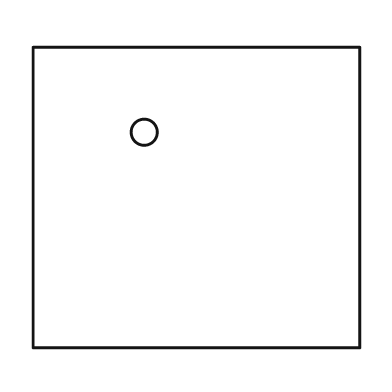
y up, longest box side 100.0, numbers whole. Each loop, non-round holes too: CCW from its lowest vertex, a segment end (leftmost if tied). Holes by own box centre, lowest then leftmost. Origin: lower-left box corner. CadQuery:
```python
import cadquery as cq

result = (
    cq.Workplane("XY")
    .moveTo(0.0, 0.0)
    .lineTo(100.0, 0.0)
    .lineTo(100.0, 92.0)
    .lineTo(0.0, 92.0)
    .close()
    .moveTo(34.0, 66.0)
    .circle(4.0)
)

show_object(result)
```